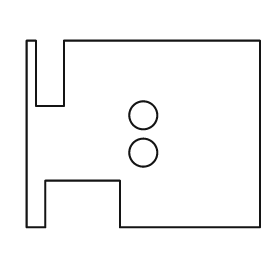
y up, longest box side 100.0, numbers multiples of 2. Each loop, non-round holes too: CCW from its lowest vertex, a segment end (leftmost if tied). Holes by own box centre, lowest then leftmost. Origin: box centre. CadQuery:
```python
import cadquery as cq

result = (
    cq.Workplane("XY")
    .moveTo(-50.0, -40.0)
    .lineTo(-42.0, -40.0)
    .lineTo(-42.0, -20.0)
    .lineTo(-10.0, -20.0)
    .lineTo(-10.0, -40.0)
    .lineTo(50.0, -40.0)
    .lineTo(50.0, 40.0)
    .lineTo(-34.0, 40.0)
    .lineTo(-34.0, 12.0)
    .lineTo(-46.0, 12.0)
    .lineTo(-46.0, 40.0)
    .lineTo(-50.0, 40.0)
    .close()
    .moveTo(0.0, -8.0)
    .circle(6.0)
    .moveTo(0.0, 8.0)
    .circle(6.0)
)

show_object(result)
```